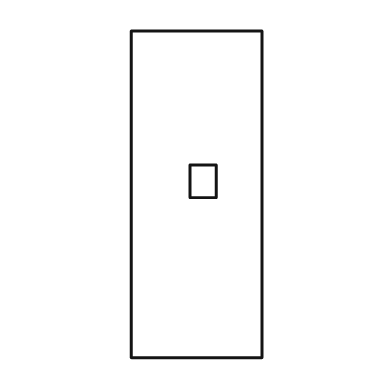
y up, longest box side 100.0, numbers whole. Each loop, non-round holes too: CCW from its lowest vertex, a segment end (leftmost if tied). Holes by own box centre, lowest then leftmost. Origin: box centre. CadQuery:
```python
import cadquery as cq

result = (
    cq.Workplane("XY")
    .moveTo(-20.0, -50.0)
    .lineTo(20.0, -50.0)
    .lineTo(20.0, 50.0)
    .lineTo(-20.0, 50.0)
    .close()
    .moveTo(-2.0, -1.0)
    .lineTo(6.0, -1.0)
    .lineTo(6.0, 9.0)
    .lineTo(-2.0, 9.0)
    .close()
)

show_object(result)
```